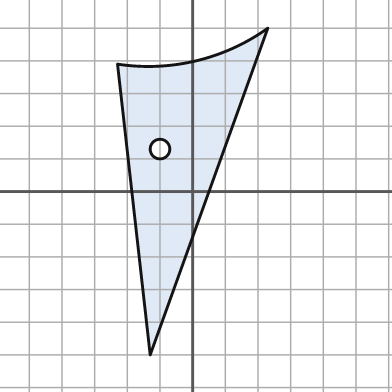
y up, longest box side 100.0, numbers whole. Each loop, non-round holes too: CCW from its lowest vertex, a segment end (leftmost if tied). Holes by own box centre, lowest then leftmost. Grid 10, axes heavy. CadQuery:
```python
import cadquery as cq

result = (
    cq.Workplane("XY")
    .moveTo(-13.0, -50.0)
    .lineTo(23.0, 50.0)
    .threePointArc((1.0, 40.0), (-23.0, 39.0))
    .close()
    .moveTo(-10.0, 13.0)
    .circle(3.0)
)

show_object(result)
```